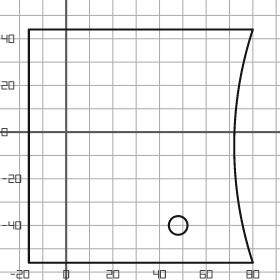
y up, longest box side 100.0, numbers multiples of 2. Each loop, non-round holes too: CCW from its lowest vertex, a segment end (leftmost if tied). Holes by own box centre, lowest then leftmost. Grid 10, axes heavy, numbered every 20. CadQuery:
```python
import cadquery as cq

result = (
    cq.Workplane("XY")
    .moveTo(-16.0, -56.0)
    .lineTo(80.0, -56.0)
    .threePointArc((72.0, -6.0), (80.0, 44.0))
    .lineTo(-16.0, 44.0)
    .close()
    .moveTo(48.0, -40.0)
    .circle(4.0)
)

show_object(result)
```